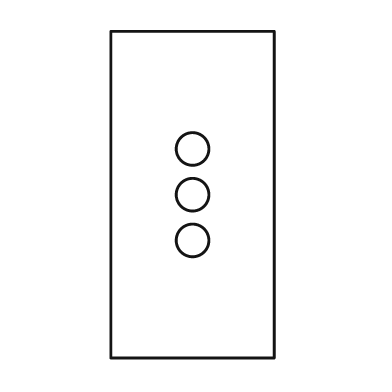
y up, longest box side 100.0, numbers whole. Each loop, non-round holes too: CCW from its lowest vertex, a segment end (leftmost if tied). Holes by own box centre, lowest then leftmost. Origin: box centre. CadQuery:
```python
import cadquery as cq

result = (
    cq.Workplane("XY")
    .moveTo(-25.0, -50.0)
    .lineTo(25.0, -50.0)
    .lineTo(25.0, 50.0)
    .lineTo(-25.0, 50.0)
    .close()
    .moveTo(0.0, -14.0)
    .circle(5.0)
    .moveTo(0.0, 0.0)
    .circle(5.0)
    .moveTo(0.0, 14.0)
    .circle(5.0)
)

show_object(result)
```